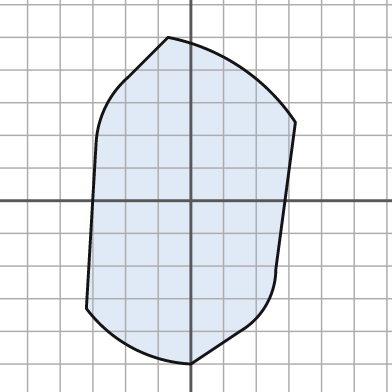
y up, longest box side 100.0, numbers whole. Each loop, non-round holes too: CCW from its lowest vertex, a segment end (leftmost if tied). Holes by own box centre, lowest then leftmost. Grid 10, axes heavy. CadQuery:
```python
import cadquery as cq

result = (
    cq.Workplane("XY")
    .moveTo(0.0, -50.0)
    .lineTo(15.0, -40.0)
    .threePointArc((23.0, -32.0), (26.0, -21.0))
    .lineTo(32.0, 24.0)
    .threePointArc((15.0, 41.0), (-7.0, 50.0))
    .lineTo(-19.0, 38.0)
    .threePointArc((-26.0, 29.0), (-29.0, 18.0))
    .lineTo(-32.0, -33.0)
    .threePointArc((-18.0, -45.0), (0.0, -50.0))
    .close()
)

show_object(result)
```